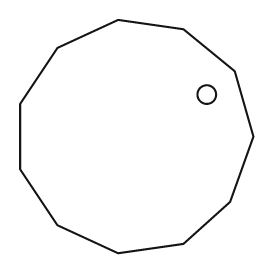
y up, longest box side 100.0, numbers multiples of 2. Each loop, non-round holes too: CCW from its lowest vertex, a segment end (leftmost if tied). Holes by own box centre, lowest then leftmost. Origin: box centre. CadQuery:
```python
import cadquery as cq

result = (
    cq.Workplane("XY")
    .moveTo(-8.0, -50.0)
    .lineTo(20.0, -46.0)
    .lineTo(40.0, -28.0)
    .lineTo(50.0, 0.0)
    .lineTo(42.0, 28.0)
    .lineTo(20.0, 46.0)
    .lineTo(-8.0, 50.0)
    .lineTo(-34.0, 38.0)
    .lineTo(-50.0, 14.0)
    .lineTo(-50.0, -14.0)
    .lineTo(-34.0, -38.0)
    .close()
    .moveTo(30.0, 18.0)
    .circle(4.0)
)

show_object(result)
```